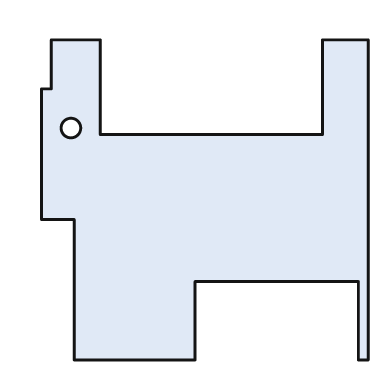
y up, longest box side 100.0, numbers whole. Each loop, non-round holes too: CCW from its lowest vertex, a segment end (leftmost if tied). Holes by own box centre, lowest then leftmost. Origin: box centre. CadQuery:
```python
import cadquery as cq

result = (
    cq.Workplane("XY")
    .moveTo(-40.0, -49.0)
    .lineTo(-3.0, -49.0)
    .lineTo(-3.0, -25.0)
    .lineTo(47.0, -25.0)
    .lineTo(47.0, -49.0)
    .lineTo(50.0, -49.0)
    .lineTo(50.0, 49.0)
    .lineTo(36.0, 49.0)
    .lineTo(36.0, 20.0)
    .lineTo(-32.0, 20.0)
    .lineTo(-32.0, 49.0)
    .lineTo(-47.0, 49.0)
    .lineTo(-47.0, 34.0)
    .lineTo(-50.0, 34.0)
    .lineTo(-50.0, -6.0)
    .lineTo(-40.0, -6.0)
    .close()
    .moveTo(-41.0, 22.0)
    .circle(3.0)
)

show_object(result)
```